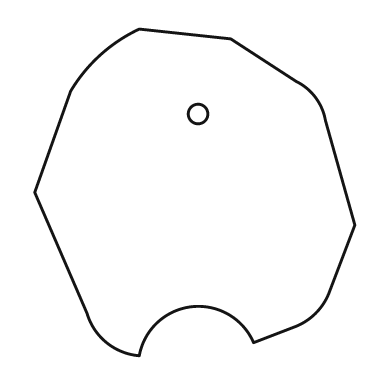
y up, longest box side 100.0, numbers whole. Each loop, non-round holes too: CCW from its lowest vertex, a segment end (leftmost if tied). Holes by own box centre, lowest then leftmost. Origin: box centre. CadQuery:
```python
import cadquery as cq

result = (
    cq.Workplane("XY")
    .moveTo(-17.0, -50.0)
    .threePointArc((-1.0, -35.0), (18.0, -46.0))
    .lineTo(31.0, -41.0)
    .threePointArc((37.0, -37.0), (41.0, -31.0))
    .lineTo(49.0, -10.0)
    .lineTo(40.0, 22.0)
    .threePointArc((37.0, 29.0), (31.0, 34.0))
    .lineTo(11.0, 47.0)
    .lineTo(-17.0, 50.0)
    .threePointArc((-29.0, 42.0), (-38.0, 31.0))
    .lineTo(-49.0, 0.0)
    .lineTo(-33.0, -37.0)
    .threePointArc((-27.0, -46.0), (-17.0, -50.0))
    .close()
    .moveTo(1.0, 24.0)
    .circle(3.0)
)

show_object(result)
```